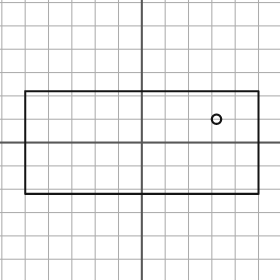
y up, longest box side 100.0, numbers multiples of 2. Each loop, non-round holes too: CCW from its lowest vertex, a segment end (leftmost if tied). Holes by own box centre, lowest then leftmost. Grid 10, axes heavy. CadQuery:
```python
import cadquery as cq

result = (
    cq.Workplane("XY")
    .moveTo(-50.0, -22.0)
    .lineTo(50.0, -22.0)
    .lineTo(50.0, 22.0)
    .lineTo(-50.0, 22.0)
    .close()
    .moveTo(32.0, 10.0)
    .circle(2.0)
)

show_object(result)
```